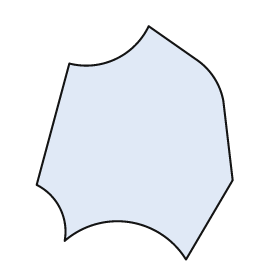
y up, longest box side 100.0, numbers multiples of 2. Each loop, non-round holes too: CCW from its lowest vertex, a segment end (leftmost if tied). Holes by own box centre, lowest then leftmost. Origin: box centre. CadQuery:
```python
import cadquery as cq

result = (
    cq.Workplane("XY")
    .moveTo(22.0, -50.0)
    .lineTo(42.0, -16.0)
    .lineTo(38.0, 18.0)
    .threePointArc((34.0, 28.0), (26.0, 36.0))
    .lineTo(6.0, 50.0)
    .threePointArc((-8.0, 36.0), (-28.0, 34.0))
    .lineTo(-42.0, -18.0)
    .threePointArc((-32.0, -28.0), (-30.0, -42.0))
    .threePointArc((-2.0, -34.0), (22.0, -50.0))
    .close()
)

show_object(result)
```